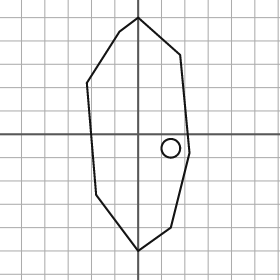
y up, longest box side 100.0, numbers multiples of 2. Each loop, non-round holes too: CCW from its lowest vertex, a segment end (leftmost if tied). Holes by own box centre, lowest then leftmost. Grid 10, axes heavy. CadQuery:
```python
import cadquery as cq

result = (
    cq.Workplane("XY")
    .moveTo(0.0, -50.0)
    .lineTo(14.0, -40.0)
    .lineTo(22.0, -8.0)
    .lineTo(18.0, 34.0)
    .lineTo(0.0, 50.0)
    .lineTo(-8.0, 44.0)
    .lineTo(-22.0, 22.0)
    .lineTo(-18.0, -26.0)
    .close()
    .moveTo(14.0, -6.0)
    .circle(4.0)
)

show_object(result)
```